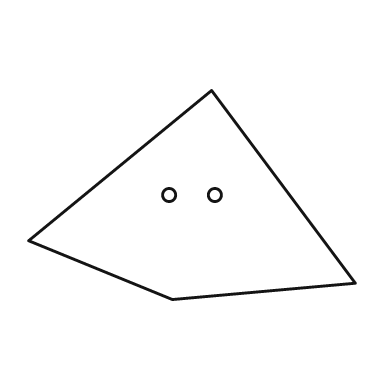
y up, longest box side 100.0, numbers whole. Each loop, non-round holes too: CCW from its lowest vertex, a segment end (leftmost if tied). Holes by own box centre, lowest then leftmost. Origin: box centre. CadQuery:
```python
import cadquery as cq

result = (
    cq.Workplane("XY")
    .moveTo(-6.0, -32.0)
    .lineTo(50.0, -27.0)
    .lineTo(6.0, 32.0)
    .lineTo(-50.0, -14.0)
    .close()
    .moveTo(-7.0, 0.0)
    .circle(2.0)
    .moveTo(7.0, 0.0)
    .circle(2.0)
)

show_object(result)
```